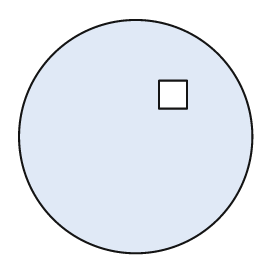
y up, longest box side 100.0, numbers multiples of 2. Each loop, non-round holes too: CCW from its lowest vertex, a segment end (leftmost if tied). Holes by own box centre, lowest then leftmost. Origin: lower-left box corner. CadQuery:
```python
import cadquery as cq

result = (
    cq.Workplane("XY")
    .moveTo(50.0, 50.0)
    .circle(50.0)
    .moveTo(60.0, 62.0)
    .lineTo(72.0, 62.0)
    .lineTo(72.0, 74.0)
    .lineTo(60.0, 74.0)
    .close()
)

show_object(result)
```